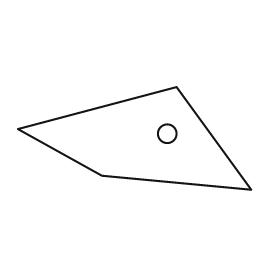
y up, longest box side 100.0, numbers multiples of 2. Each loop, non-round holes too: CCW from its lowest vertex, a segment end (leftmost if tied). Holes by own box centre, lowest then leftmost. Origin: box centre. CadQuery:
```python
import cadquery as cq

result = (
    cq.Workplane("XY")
    .moveTo(50.0, -22.0)
    .lineTo(18.0, 22.0)
    .lineTo(-50.0, 4.0)
    .lineTo(-14.0, -16.0)
    .close()
    .moveTo(14.0, 2.0)
    .circle(4.0)
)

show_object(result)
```